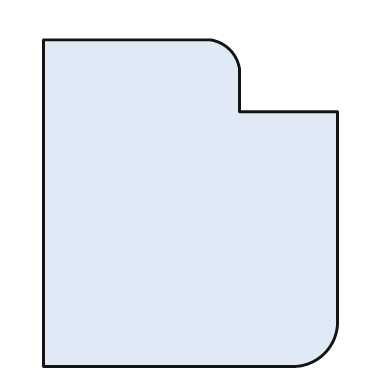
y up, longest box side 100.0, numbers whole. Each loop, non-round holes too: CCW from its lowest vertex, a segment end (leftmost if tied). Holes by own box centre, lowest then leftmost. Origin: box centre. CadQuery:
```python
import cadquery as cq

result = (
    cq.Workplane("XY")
    .moveTo(-45.0, -50.0)
    .lineTo(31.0, -50.0)
    .threePointArc((41.0, -46.0), (45.0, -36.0))
    .lineTo(45.0, 28.0)
    .lineTo(15.0, 28.0)
    .lineTo(15.0, 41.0)
    .threePointArc((12.0, 47.0), (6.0, 50.0))
    .lineTo(-45.0, 50.0)
    .close()
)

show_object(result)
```